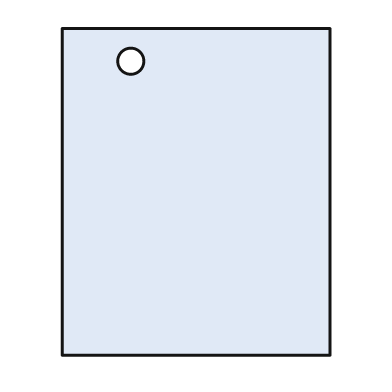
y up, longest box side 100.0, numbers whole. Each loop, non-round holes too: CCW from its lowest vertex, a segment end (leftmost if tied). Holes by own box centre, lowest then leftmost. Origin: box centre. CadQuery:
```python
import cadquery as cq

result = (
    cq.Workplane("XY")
    .moveTo(-41.0, -50.0)
    .lineTo(41.0, -50.0)
    .lineTo(41.0, 50.0)
    .lineTo(-41.0, 50.0)
    .close()
    .moveTo(-20.0, 40.0)
    .circle(4.0)
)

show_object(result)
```